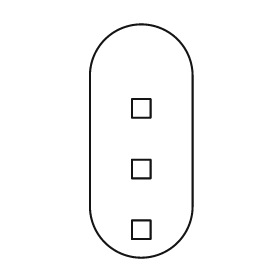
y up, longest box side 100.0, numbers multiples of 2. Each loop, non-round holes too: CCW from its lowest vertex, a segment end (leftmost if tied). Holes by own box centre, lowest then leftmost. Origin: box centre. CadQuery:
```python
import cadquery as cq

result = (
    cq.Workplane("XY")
    .moveTo(-22.0, -28.0)
    .threePointArc((0.0, -50.0), (22.0, -28.0))
    .lineTo(22.0, 28.0)
    .threePointArc((0.0, 50.0), (-22.0, 28.0))
    .close()
    .moveTo(-4.0, -42.0)
    .lineTo(4.0, -42.0)
    .lineTo(4.0, -34.0)
    .lineTo(-4.0, -34.0)
    .close()
    .moveTo(-4.0, -16.0)
    .lineTo(4.0, -16.0)
    .lineTo(4.0, -8.0)
    .lineTo(-4.0, -8.0)
    .close()
    .moveTo(-4.0, 10.0)
    .lineTo(4.0, 10.0)
    .lineTo(4.0, 18.0)
    .lineTo(-4.0, 18.0)
    .close()
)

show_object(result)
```